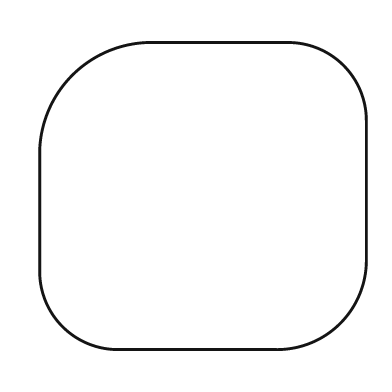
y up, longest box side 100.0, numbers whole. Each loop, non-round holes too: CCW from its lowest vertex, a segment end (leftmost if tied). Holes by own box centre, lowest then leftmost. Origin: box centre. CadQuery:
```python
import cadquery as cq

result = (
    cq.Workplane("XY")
    .moveTo(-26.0, -47.0)
    .lineTo(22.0, -47.0)
    .threePointArc((42.0, -39.0), (50.0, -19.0))
    .lineTo(50.0, 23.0)
    .threePointArc((43.0, 40.0), (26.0, 47.0))
    .lineTo(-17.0, 47.0)
    .threePointArc((-40.0, 37.0), (-50.0, 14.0))
    .lineTo(-50.0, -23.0)
    .threePointArc((-43.0, -40.0), (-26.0, -47.0))
    .close()
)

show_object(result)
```